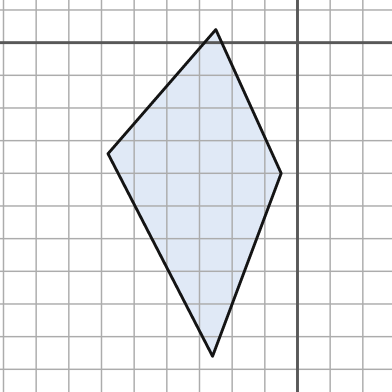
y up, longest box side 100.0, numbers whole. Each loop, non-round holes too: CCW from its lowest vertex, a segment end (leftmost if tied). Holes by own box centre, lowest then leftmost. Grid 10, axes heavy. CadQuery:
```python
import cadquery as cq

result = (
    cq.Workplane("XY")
    .moveTo(-26.0, -96.0)
    .lineTo(-5.0, -40.0)
    .lineTo(-25.0, 4.0)
    .lineTo(-58.0, -34.0)
    .close()
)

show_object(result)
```